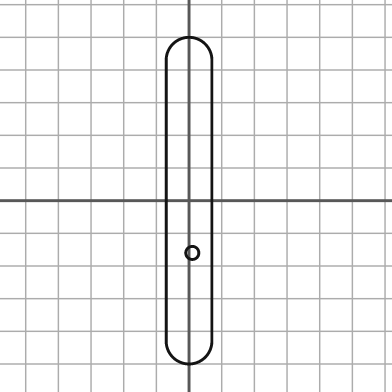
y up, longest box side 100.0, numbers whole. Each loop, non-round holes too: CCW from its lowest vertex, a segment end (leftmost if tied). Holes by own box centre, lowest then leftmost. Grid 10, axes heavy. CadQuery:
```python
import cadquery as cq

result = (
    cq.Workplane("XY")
    .moveTo(-7.0, -43.0)
    .threePointArc((0.0, -50.0), (7.0, -43.0))
    .lineTo(7.0, 43.0)
    .threePointArc((0.0, 50.0), (-7.0, 43.0))
    .close()
    .moveTo(1.0, -16.0)
    .circle(2.0)
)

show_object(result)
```